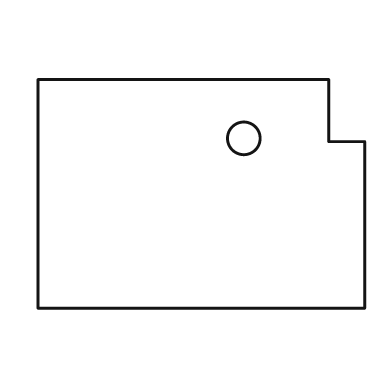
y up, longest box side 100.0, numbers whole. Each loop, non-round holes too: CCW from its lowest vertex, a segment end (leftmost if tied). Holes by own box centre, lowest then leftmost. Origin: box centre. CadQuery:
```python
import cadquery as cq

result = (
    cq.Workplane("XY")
    .moveTo(-50.0, -35.0)
    .lineTo(50.0, -35.0)
    .lineTo(50.0, 16.0)
    .lineTo(39.0, 16.0)
    .lineTo(39.0, 35.0)
    .lineTo(-50.0, 35.0)
    .close()
    .moveTo(13.0, 17.0)
    .circle(5.0)
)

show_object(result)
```